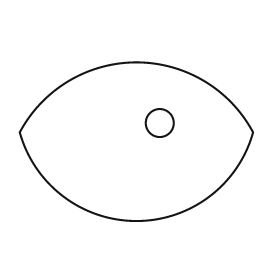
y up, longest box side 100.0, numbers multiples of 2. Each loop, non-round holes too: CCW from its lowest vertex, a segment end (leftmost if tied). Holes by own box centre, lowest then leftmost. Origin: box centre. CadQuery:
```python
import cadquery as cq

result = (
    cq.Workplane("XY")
    .moveTo(-50.0, 4.0)
    .threePointArc((0.0, -34.0), (50.0, 4.0))
    .threePointArc((0.0, 34.0), (-50.0, 4.0))
    .close()
    .moveTo(10.0, 8.0)
    .circle(6.0)
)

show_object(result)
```